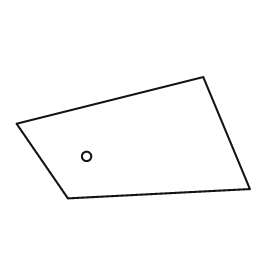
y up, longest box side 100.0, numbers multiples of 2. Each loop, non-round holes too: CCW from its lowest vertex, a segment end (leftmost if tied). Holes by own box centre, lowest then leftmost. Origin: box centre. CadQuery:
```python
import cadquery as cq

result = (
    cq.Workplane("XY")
    .moveTo(-28.0, -26.0)
    .lineTo(50.0, -22.0)
    .lineTo(30.0, 26.0)
    .lineTo(-50.0, 6.0)
    .close()
    .moveTo(-20.0, -8.0)
    .circle(2.0)
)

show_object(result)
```